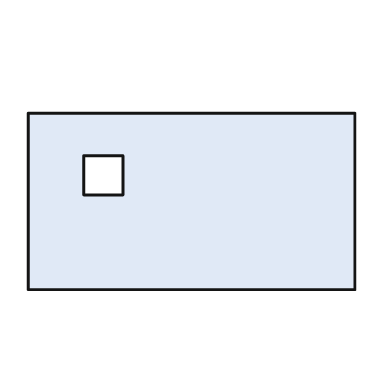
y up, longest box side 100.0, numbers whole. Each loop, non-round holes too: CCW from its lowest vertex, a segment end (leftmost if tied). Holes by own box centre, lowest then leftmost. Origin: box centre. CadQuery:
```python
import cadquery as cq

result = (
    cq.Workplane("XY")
    .moveTo(-50.0, -27.0)
    .lineTo(50.0, -27.0)
    .lineTo(50.0, 27.0)
    .lineTo(-50.0, 27.0)
    .close()
    .moveTo(-33.0, 2.0)
    .lineTo(-21.0, 2.0)
    .lineTo(-21.0, 14.0)
    .lineTo(-33.0, 14.0)
    .close()
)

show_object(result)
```